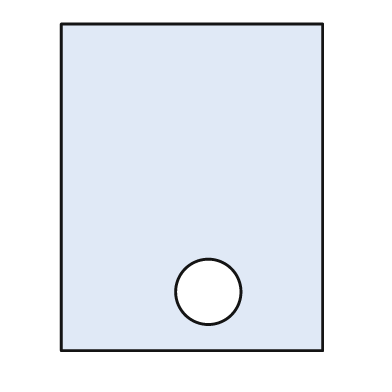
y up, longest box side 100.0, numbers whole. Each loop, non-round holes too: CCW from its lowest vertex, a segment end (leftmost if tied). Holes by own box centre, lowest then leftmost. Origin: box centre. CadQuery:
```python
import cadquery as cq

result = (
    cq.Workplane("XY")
    .moveTo(-40.0, -50.0)
    .lineTo(40.0, -50.0)
    .lineTo(40.0, 50.0)
    .lineTo(-40.0, 50.0)
    .close()
    .moveTo(5.0, -32.0)
    .circle(10.0)
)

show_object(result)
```